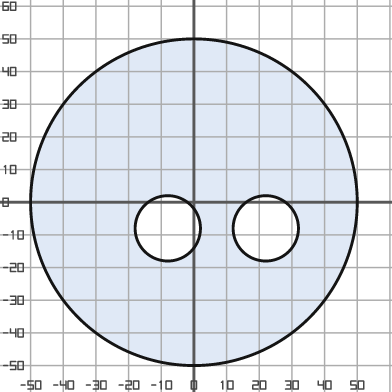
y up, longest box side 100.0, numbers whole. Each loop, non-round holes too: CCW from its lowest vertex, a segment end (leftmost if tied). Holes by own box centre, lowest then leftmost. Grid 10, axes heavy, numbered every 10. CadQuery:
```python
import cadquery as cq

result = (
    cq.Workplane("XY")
    .moveTo(0.0, 0.0)
    .circle(50.0)
    .moveTo(-8.0, -8.0)
    .circle(10.0)
    .moveTo(22.0, -8.0)
    .circle(10.0)
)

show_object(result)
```